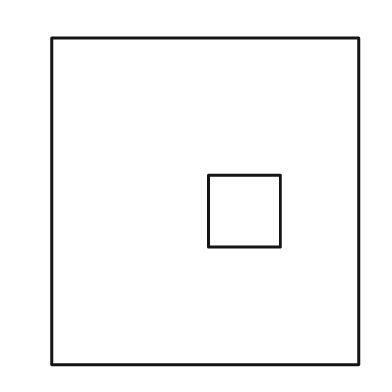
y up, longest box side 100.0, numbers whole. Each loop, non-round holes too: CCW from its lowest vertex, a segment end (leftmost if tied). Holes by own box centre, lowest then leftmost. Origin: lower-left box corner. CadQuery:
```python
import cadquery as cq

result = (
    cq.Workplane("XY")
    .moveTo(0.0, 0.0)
    .lineTo(94.0, 0.0)
    .lineTo(94.0, 100.0)
    .lineTo(0.0, 100.0)
    .close()
    .moveTo(48.0, 36.0)
    .lineTo(70.0, 36.0)
    .lineTo(70.0, 58.0)
    .lineTo(48.0, 58.0)
    .close()
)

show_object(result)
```